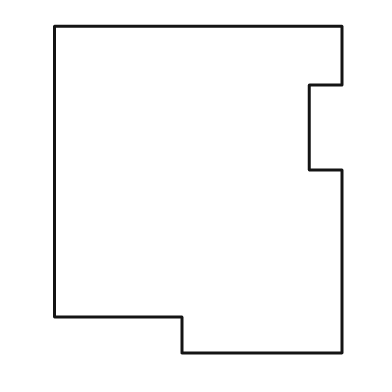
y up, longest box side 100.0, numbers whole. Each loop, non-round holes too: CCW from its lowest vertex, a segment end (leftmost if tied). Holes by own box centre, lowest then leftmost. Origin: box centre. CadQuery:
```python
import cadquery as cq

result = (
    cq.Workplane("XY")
    .moveTo(-5.0, -50.0)
    .lineTo(44.0, -50.0)
    .lineTo(44.0, 6.0)
    .lineTo(34.0, 6.0)
    .lineTo(34.0, 32.0)
    .lineTo(44.0, 32.0)
    .lineTo(44.0, 50.0)
    .lineTo(-44.0, 50.0)
    .lineTo(-44.0, -39.0)
    .lineTo(-5.0, -39.0)
    .close()
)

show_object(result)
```